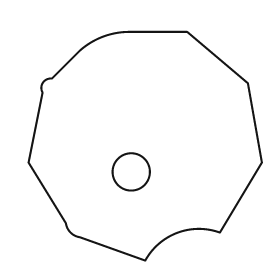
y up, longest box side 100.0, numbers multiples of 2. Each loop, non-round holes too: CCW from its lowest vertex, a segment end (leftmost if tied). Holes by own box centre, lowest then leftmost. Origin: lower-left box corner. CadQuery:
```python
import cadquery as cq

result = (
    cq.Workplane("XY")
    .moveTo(50.0, 0.0)
    .threePointArc((64.0, 12.0), (82.0, 12.0))
    .lineTo(100.0, 42.0)
    .lineTo(94.0, 76.0)
    .lineTo(68.0, 98.0)
    .lineTo(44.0, 98.0)
    .threePointArc((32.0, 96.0), (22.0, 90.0))
    .lineTo(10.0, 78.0)
    .threePointArc((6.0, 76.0), (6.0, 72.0))
    .lineTo(0.0, 42.0)
    .lineTo(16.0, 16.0)
    .threePointArc((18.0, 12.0), (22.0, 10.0))
    .close()
    .moveTo(44.0, 38.0)
    .circle(8.0)
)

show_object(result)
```